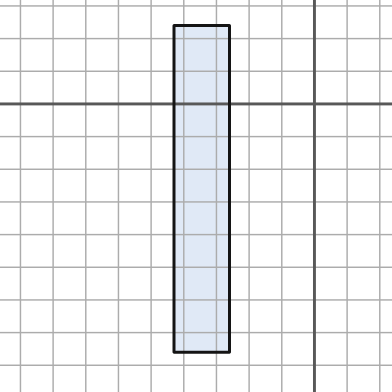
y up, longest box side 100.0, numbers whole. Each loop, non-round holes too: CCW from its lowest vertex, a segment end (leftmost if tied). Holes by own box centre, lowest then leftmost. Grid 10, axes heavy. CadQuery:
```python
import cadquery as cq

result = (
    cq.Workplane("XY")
    .moveTo(-43.0, -76.0)
    .lineTo(-26.0, -76.0)
    .lineTo(-26.0, 24.0)
    .lineTo(-43.0, 24.0)
    .close()
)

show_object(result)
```